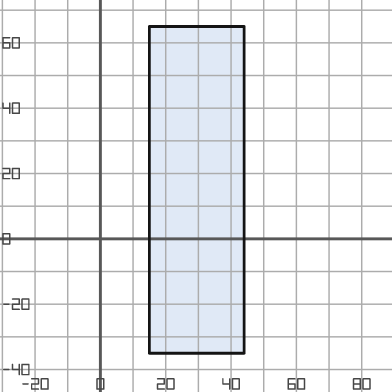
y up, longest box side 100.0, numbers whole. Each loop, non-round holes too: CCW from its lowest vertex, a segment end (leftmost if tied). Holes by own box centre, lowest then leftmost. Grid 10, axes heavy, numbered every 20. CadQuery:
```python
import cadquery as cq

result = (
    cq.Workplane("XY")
    .moveTo(15.0, -35.0)
    .lineTo(44.0, -35.0)
    .lineTo(44.0, 65.0)
    .lineTo(15.0, 65.0)
    .close()
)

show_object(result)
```